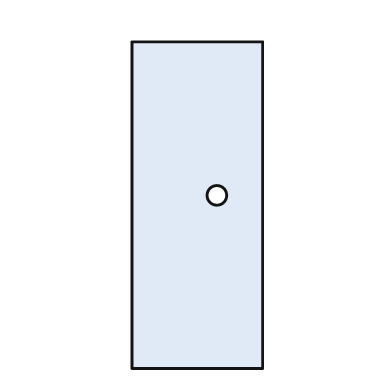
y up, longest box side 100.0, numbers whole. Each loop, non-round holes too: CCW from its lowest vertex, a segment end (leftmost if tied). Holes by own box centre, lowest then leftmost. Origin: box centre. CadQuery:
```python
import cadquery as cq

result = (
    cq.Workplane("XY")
    .moveTo(-20.0, -50.0)
    .lineTo(20.0, -50.0)
    .lineTo(20.0, 50.0)
    .lineTo(-20.0, 50.0)
    .close()
    .moveTo(6.0, 3.0)
    .circle(3.0)
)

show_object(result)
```